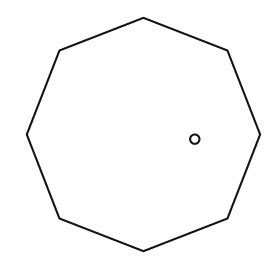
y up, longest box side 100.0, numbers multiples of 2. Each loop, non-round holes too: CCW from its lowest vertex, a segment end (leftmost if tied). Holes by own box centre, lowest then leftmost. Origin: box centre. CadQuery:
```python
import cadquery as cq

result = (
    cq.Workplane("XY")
    .moveTo(0.0, -50.0)
    .lineTo(36.0, -36.0)
    .lineTo(50.0, 0.0)
    .lineTo(36.0, 36.0)
    .lineTo(0.0, 50.0)
    .lineTo(-36.0, 36.0)
    .lineTo(-50.0, 0.0)
    .lineTo(-36.0, -36.0)
    .close()
    .moveTo(22.0, -2.0)
    .circle(2.0)
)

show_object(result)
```